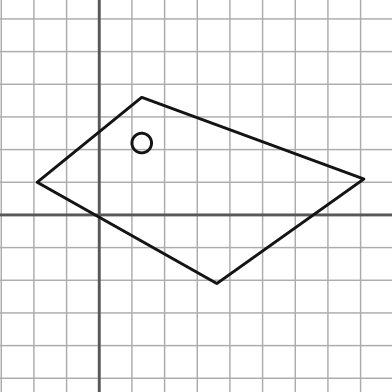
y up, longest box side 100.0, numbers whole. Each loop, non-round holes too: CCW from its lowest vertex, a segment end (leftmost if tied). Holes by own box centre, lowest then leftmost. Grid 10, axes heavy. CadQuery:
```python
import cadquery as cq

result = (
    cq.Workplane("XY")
    .moveTo(36.0, -21.0)
    .lineTo(81.0, 11.0)
    .lineTo(13.0, 36.0)
    .lineTo(-19.0, 10.0)
    .close()
    .moveTo(13.0, 22.0)
    .circle(3.0)
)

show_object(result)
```